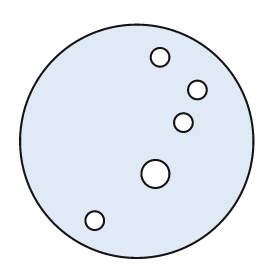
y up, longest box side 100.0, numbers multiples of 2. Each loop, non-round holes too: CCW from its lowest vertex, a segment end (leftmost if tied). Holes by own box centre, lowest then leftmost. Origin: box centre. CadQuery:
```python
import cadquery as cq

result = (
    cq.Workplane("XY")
    .moveTo(0.0, 0.0)
    .circle(50.0)
    .moveTo(-18.0, -34.0)
    .circle(4.0)
    .moveTo(8.0, -14.0)
    .circle(6.0)
    .moveTo(20.0, 8.0)
    .circle(4.0)
    .moveTo(26.0, 22.0)
    .circle(4.0)
    .moveTo(10.0, 36.0)
    .circle(4.0)
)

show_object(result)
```